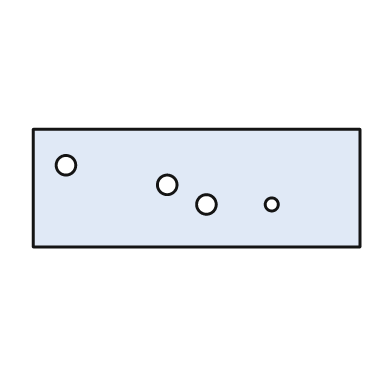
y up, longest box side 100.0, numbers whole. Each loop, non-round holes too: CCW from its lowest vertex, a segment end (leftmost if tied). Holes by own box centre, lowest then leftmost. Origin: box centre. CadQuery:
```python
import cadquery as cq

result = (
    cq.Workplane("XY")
    .moveTo(-50.0, -18.0)
    .lineTo(50.0, -18.0)
    .lineTo(50.0, 18.0)
    .lineTo(-50.0, 18.0)
    .close()
    .moveTo(3.0, -5.0)
    .circle(3.0)
    .moveTo(23.0, -5.0)
    .circle(2.0)
    .moveTo(-9.0, 1.0)
    .circle(3.0)
    .moveTo(-40.0, 7.0)
    .circle(3.0)
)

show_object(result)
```